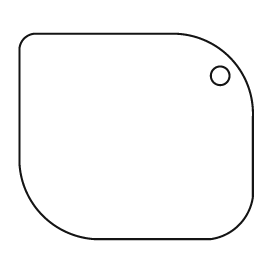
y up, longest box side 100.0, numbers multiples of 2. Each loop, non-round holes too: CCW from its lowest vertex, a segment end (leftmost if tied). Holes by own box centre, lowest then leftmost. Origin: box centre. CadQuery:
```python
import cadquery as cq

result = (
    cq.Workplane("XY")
    .moveTo(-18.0, -44.0)
    .lineTo(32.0, -44.0)
    .threePointArc((44.0, -38.0), (50.0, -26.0))
    .lineTo(50.0, 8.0)
    .threePointArc((40.0, 34.0), (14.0, 44.0))
    .lineTo(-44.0, 44.0)
    .threePointArc((-48.0, 42.0), (-50.0, 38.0))
    .lineTo(-50.0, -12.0)
    .threePointArc((-40.0, -34.0), (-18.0, -44.0))
    .close()
    .moveTo(36.0, 26.0)
    .circle(4.0)
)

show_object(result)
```